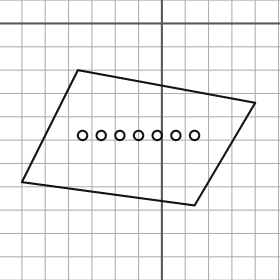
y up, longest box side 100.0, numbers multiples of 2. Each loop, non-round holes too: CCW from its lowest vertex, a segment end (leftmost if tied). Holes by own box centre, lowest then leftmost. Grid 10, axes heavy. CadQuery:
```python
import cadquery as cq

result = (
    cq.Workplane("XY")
    .moveTo(14.0, -78.0)
    .lineTo(40.0, -34.0)
    .lineTo(-36.0, -20.0)
    .lineTo(-60.0, -68.0)
    .close()
    .moveTo(-34.0, -48.0)
    .circle(2.0)
    .moveTo(-26.0, -48.0)
    .circle(2.0)
    .moveTo(-18.0, -48.0)
    .circle(2.0)
    .moveTo(-10.0, -48.0)
    .circle(2.0)
    .moveTo(-2.0, -48.0)
    .circle(2.0)
    .moveTo(6.0, -48.0)
    .circle(2.0)
    .moveTo(14.0, -48.0)
    .circle(2.0)
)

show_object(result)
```